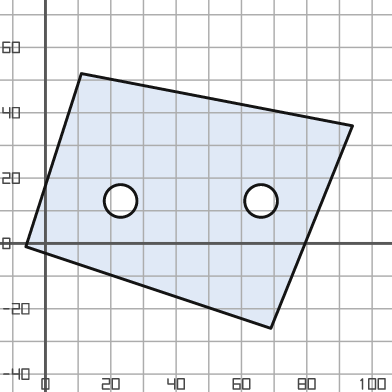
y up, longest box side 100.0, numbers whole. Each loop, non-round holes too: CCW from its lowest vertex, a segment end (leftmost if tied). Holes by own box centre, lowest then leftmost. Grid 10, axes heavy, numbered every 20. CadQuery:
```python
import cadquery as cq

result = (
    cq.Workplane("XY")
    .moveTo(69.0, -26.0)
    .lineTo(94.0, 36.0)
    .lineTo(11.0, 52.0)
    .lineTo(-6.0, -1.0)
    .close()
    .moveTo(23.0, 13.0)
    .circle(5.0)
    .moveTo(66.0, 13.0)
    .circle(5.0)
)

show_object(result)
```